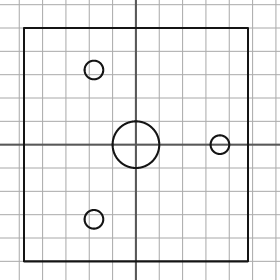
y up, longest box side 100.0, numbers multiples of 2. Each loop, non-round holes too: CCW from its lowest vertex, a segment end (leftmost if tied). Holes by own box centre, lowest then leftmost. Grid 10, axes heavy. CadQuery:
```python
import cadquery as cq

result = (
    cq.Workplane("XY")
    .moveTo(-48.0, -50.0)
    .lineTo(48.0, -50.0)
    .lineTo(48.0, 50.0)
    .lineTo(-48.0, 50.0)
    .close()
    .moveTo(-18.0, -32.0)
    .circle(4.0)
    .moveTo(0.0, 0.0)
    .circle(10.0)
    .moveTo(36.0, 0.0)
    .circle(4.0)
    .moveTo(-18.0, 32.0)
    .circle(4.0)
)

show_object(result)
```